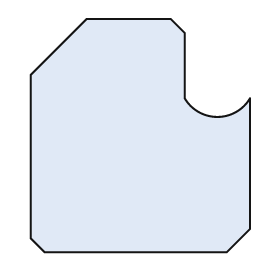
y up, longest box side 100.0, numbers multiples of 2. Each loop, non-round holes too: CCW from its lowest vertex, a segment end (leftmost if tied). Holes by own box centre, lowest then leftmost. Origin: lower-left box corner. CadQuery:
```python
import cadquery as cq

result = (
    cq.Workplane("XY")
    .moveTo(6.0, 0.0)
    .lineTo(84.0, 0.0)
    .lineTo(94.0, 10.0)
    .lineTo(94.0, 66.0)
    .threePointArc((80.0, 58.0), (66.0, 66.0))
    .lineTo(66.0, 94.0)
    .lineTo(60.0, 100.0)
    .lineTo(24.0, 100.0)
    .lineTo(0.0, 76.0)
    .lineTo(0.0, 6.0)
    .close()
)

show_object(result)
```